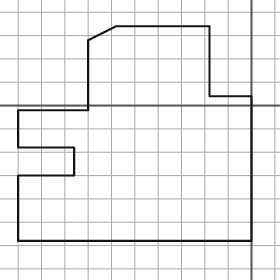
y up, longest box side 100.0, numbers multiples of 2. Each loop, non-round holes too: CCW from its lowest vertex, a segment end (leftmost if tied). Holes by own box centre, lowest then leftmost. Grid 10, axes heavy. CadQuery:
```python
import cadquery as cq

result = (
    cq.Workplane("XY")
    .moveTo(-100.0, -58.0)
    .lineTo(0.0, -58.0)
    .lineTo(0.0, 4.0)
    .lineTo(-18.0, 4.0)
    .lineTo(-18.0, 34.0)
    .lineTo(-58.0, 34.0)
    .lineTo(-70.0, 28.0)
    .lineTo(-70.0, -2.0)
    .lineTo(-100.0, -2.0)
    .lineTo(-100.0, -18.0)
    .lineTo(-76.0, -18.0)
    .lineTo(-76.0, -30.0)
    .lineTo(-100.0, -30.0)
    .close()
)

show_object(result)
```